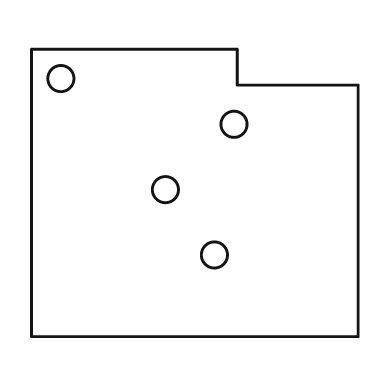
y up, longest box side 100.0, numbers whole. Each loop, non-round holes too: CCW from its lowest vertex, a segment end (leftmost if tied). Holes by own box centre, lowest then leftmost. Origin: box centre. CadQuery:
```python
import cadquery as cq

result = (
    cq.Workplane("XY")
    .moveTo(-50.0, -44.0)
    .lineTo(50.0, -44.0)
    .lineTo(50.0, 33.0)
    .lineTo(13.0, 33.0)
    .lineTo(13.0, 44.0)
    .lineTo(-50.0, 44.0)
    .close()
    .moveTo(6.0, -19.0)
    .circle(4.0)
    .moveTo(-9.0, 1.0)
    .circle(4.0)
    .moveTo(12.0, 21.0)
    .circle(4.0)
    .moveTo(-41.0, 35.0)
    .circle(4.0)
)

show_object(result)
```